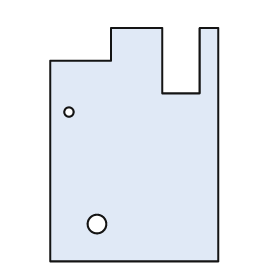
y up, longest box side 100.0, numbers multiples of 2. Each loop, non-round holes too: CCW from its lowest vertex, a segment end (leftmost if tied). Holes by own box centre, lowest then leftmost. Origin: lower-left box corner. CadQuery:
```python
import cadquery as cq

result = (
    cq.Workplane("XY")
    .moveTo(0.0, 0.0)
    .lineTo(72.0, 0.0)
    .lineTo(72.0, 100.0)
    .lineTo(64.0, 100.0)
    .lineTo(64.0, 72.0)
    .lineTo(48.0, 72.0)
    .lineTo(48.0, 100.0)
    .lineTo(26.0, 100.0)
    .lineTo(26.0, 86.0)
    .lineTo(0.0, 86.0)
    .close()
    .moveTo(20.0, 16.0)
    .circle(4.0)
    .moveTo(8.0, 64.0)
    .circle(2.0)
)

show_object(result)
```